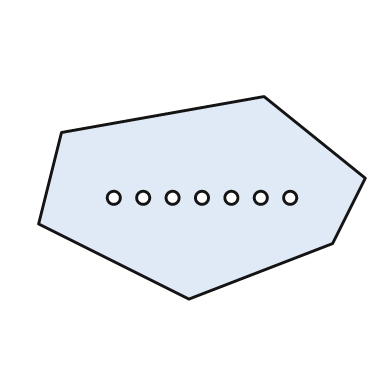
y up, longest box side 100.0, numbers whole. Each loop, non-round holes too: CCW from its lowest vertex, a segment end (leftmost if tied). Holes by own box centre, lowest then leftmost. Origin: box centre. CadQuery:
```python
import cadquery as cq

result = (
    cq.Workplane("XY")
    .moveTo(-4.0, -31.0)
    .lineTo(40.0, -14.0)
    .lineTo(50.0, 6.0)
    .lineTo(19.0, 31.0)
    .lineTo(-43.0, 20.0)
    .lineTo(-50.0, -8.0)
    .close()
    .moveTo(-27.0, 0.0)
    .circle(2.0)
    .moveTo(-18.0, 0.0)
    .circle(2.0)
    .moveTo(-9.0, 0.0)
    .circle(2.0)
    .moveTo(0.0, 0.0)
    .circle(2.0)
    .moveTo(9.0, 0.0)
    .circle(2.0)
    .moveTo(18.0, 0.0)
    .circle(2.0)
    .moveTo(27.0, 0.0)
    .circle(2.0)
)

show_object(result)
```